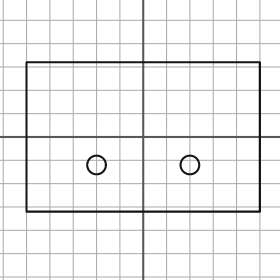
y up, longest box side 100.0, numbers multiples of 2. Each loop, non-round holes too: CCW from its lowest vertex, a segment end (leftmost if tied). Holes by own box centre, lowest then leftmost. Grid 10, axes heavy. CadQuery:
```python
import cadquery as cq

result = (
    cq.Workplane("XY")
    .moveTo(-50.0, -32.0)
    .lineTo(50.0, -32.0)
    .lineTo(50.0, 32.0)
    .lineTo(-50.0, 32.0)
    .close()
    .moveTo(-20.0, -12.0)
    .circle(4.0)
    .moveTo(20.0, -12.0)
    .circle(4.0)
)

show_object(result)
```